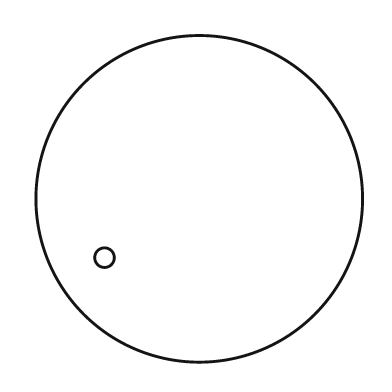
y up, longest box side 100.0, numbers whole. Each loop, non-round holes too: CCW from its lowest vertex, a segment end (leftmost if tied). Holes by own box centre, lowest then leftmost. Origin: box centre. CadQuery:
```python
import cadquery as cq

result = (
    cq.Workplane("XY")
    .moveTo(0.0, 0.0)
    .circle(50.0)
    .moveTo(-29.0, -18.0)
    .circle(3.0)
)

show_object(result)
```